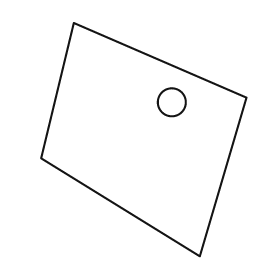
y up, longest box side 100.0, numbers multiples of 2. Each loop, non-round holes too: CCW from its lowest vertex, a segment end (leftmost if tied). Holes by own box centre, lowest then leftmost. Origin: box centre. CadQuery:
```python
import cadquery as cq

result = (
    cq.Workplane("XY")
    .moveTo(24.0, -50.0)
    .lineTo(44.0, 18.0)
    .lineTo(-30.0, 50.0)
    .lineTo(-44.0, -8.0)
    .close()
    .moveTo(12.0, 16.0)
    .circle(6.0)
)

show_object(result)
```